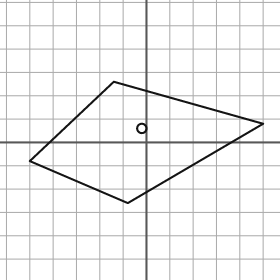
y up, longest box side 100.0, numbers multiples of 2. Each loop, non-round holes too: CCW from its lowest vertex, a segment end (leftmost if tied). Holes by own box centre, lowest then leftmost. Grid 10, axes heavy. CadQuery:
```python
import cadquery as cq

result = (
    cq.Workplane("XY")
    .moveTo(-8.0, -26.0)
    .lineTo(50.0, 8.0)
    .lineTo(-14.0, 26.0)
    .lineTo(-50.0, -8.0)
    .close()
    .moveTo(-2.0, 6.0)
    .circle(2.0)
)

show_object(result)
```